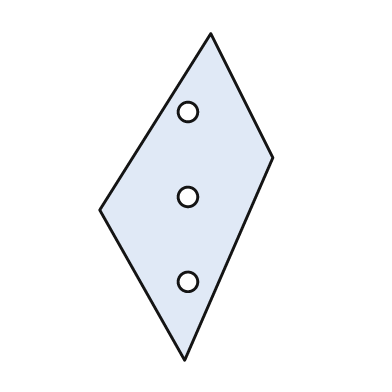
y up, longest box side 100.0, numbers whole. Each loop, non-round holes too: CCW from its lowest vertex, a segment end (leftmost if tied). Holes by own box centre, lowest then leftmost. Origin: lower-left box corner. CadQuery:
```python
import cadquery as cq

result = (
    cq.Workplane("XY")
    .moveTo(26.0, 0.0)
    .lineTo(53.0, 62.0)
    .lineTo(34.0, 100.0)
    .lineTo(0.0, 46.0)
    .close()
    .moveTo(27.0, 24.0)
    .circle(3.0)
    .moveTo(27.0, 50.0)
    .circle(3.0)
    .moveTo(27.0, 76.0)
    .circle(3.0)
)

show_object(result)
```